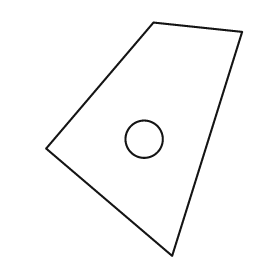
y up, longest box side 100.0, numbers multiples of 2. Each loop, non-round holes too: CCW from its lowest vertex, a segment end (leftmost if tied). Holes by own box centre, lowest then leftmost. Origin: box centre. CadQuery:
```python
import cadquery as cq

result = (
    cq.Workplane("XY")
    .moveTo(12.0, -50.0)
    .lineTo(42.0, 46.0)
    .lineTo(4.0, 50.0)
    .lineTo(-42.0, -4.0)
    .close()
    .moveTo(0.0, 0.0)
    .circle(8.0)
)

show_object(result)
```